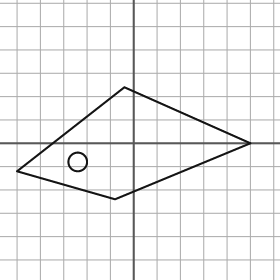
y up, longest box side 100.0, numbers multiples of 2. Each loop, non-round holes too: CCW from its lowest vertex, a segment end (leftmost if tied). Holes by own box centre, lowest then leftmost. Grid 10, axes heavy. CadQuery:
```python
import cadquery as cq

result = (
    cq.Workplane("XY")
    .moveTo(-8.0, -24.0)
    .lineTo(50.0, 0.0)
    .lineTo(-4.0, 24.0)
    .lineTo(-50.0, -12.0)
    .close()
    .moveTo(-24.0, -8.0)
    .circle(4.0)
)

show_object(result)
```